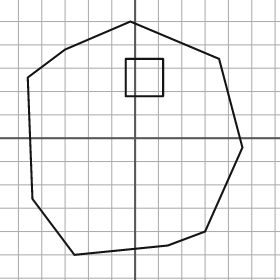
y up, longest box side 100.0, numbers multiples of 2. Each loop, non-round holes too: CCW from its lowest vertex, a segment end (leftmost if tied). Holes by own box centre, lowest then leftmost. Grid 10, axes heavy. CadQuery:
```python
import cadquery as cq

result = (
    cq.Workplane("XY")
    .moveTo(-26.0, -50.0)
    .lineTo(14.0, -46.0)
    .lineTo(30.0, -40.0)
    .lineTo(46.0, -4.0)
    .lineTo(36.0, 34.0)
    .lineTo(-2.0, 50.0)
    .lineTo(-30.0, 38.0)
    .lineTo(-46.0, 26.0)
    .lineTo(-44.0, -26.0)
    .close()
    .moveTo(-4.0, 18.0)
    .lineTo(12.0, 18.0)
    .lineTo(12.0, 34.0)
    .lineTo(-4.0, 34.0)
    .close()
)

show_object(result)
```